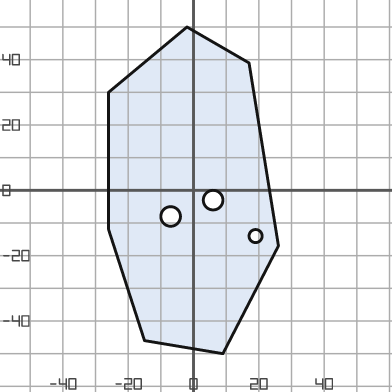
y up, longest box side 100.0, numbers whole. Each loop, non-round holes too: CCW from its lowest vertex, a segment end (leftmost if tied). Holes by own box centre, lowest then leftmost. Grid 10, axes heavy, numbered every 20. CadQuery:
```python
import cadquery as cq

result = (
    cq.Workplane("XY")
    .moveTo(9.0, -50.0)
    .lineTo(26.0, -17.0)
    .lineTo(17.0, 39.0)
    .lineTo(-2.0, 50.0)
    .lineTo(-26.0, 30.0)
    .lineTo(-26.0, -12.0)
    .lineTo(-15.0, -46.0)
    .close()
    .moveTo(19.0, -14.0)
    .circle(2.0)
    .moveTo(-7.0, -8.0)
    .circle(3.0)
    .moveTo(6.0, -3.0)
    .circle(3.0)
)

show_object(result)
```